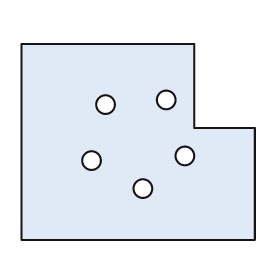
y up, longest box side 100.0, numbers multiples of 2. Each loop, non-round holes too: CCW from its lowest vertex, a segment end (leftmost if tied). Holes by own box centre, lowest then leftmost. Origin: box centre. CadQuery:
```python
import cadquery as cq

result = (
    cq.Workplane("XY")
    .moveTo(-50.0, -42.0)
    .lineTo(50.0, -42.0)
    .lineTo(50.0, 6.0)
    .lineTo(24.0, 6.0)
    .lineTo(24.0, 42.0)
    .lineTo(-50.0, 42.0)
    .close()
    .moveTo(2.0, -20.0)
    .circle(4.0)
    .moveTo(-20.0, -8.0)
    .circle(4.0)
    .moveTo(20.0, -6.0)
    .circle(4.0)
    .moveTo(-14.0, 16.0)
    .circle(4.0)
    .moveTo(12.0, 18.0)
    .circle(4.0)
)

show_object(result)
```